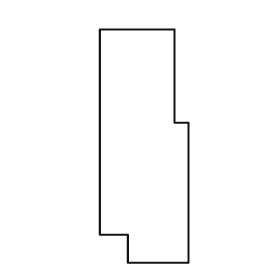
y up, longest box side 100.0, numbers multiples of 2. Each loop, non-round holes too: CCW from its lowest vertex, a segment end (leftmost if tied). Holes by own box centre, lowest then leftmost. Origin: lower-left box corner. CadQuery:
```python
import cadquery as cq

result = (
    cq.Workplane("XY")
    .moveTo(12.0, 0.0)
    .lineTo(38.0, 0.0)
    .lineTo(38.0, 60.0)
    .lineTo(32.0, 60.0)
    .lineTo(32.0, 100.0)
    .lineTo(0.0, 100.0)
    .lineTo(0.0, 12.0)
    .lineTo(12.0, 12.0)
    .close()
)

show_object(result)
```